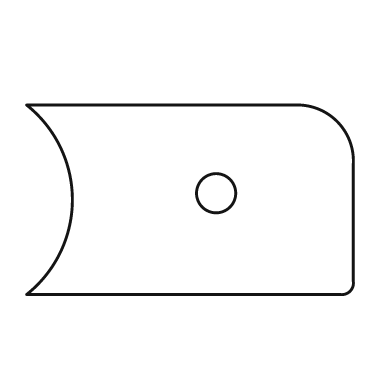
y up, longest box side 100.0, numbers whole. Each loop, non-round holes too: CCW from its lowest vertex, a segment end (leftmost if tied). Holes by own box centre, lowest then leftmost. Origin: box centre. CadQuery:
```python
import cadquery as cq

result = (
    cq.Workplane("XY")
    .moveTo(-50.0, -29.0)
    .lineTo(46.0, -29.0)
    .threePointArc((49.0, -28.0), (50.0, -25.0))
    .lineTo(50.0, 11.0)
    .threePointArc((45.0, 24.0), (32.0, 29.0))
    .lineTo(-50.0, 29.0)
    .threePointArc((-36.0, 0.0), (-50.0, -29.0))
    .close()
    .moveTo(8.0, 2.0)
    .circle(6.0)
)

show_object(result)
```